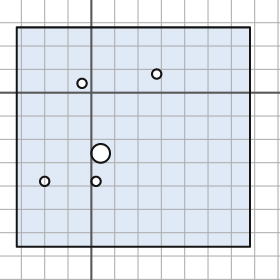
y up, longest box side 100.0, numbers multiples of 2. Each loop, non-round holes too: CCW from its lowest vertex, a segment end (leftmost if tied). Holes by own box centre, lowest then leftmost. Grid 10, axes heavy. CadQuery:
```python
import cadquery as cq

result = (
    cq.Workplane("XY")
    .moveTo(-32.0, -66.0)
    .lineTo(68.0, -66.0)
    .lineTo(68.0, 28.0)
    .lineTo(-32.0, 28.0)
    .close()
    .moveTo(-20.0, -38.0)
    .circle(2.0)
    .moveTo(2.0, -38.0)
    .circle(2.0)
    .moveTo(4.0, -26.0)
    .circle(4.0)
    .moveTo(-4.0, 4.0)
    .circle(2.0)
    .moveTo(28.0, 8.0)
    .circle(2.0)
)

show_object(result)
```